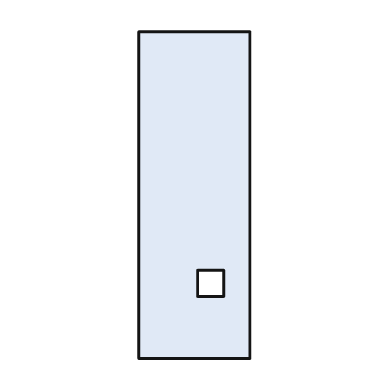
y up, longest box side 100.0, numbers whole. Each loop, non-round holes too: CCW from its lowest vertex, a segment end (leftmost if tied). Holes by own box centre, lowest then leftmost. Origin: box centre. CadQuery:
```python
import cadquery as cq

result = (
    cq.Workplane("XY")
    .moveTo(-17.0, -50.0)
    .lineTo(17.0, -50.0)
    .lineTo(17.0, 50.0)
    .lineTo(-17.0, 50.0)
    .close()
    .moveTo(1.0, -31.0)
    .lineTo(9.0, -31.0)
    .lineTo(9.0, -23.0)
    .lineTo(1.0, -23.0)
    .close()
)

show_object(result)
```